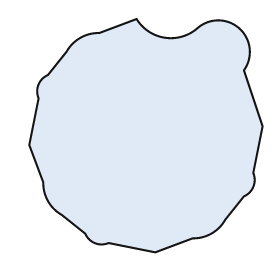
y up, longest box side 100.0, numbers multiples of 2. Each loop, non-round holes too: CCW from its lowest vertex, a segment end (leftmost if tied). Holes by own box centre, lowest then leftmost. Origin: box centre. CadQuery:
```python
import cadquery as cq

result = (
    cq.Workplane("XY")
    .moveTo(4.0, -50.0)
    .lineTo(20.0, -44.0)
    .threePointArc((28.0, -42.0), (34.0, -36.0))
    .lineTo(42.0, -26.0)
    .threePointArc((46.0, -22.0), (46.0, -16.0))
    .lineTo(50.0, 4.0)
    .lineTo(42.0, 28.0)
    .threePointArc((40.0, 46.0), (22.0, 46.0))
    .threePointArc((8.0, 42.0), (-4.0, 50.0))
    .lineTo(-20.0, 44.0)
    .threePointArc((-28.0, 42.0), (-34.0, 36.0))
    .lineTo(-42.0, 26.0)
    .threePointArc((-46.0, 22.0), (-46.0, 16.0))
    .lineTo(-50.0, -4.0)
    .lineTo(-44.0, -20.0)
    .threePointArc((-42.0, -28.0), (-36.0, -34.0))
    .lineTo(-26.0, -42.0)
    .threePointArc((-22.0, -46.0), (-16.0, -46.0))
    .close()
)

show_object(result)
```